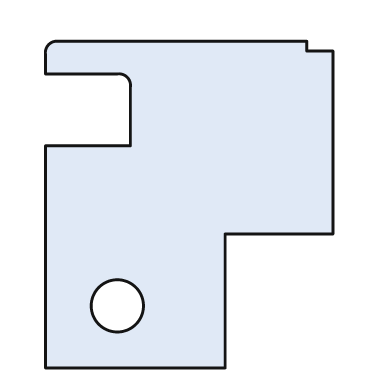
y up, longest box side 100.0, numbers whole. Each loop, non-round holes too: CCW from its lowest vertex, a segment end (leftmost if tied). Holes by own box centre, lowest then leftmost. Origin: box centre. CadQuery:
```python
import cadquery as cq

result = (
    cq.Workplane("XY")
    .moveTo(-44.0, -50.0)
    .lineTo(11.0, -50.0)
    .lineTo(11.0, -9.0)
    .lineTo(44.0, -9.0)
    .lineTo(44.0, 47.0)
    .lineTo(36.0, 47.0)
    .lineTo(36.0, 50.0)
    .lineTo(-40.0, 50.0)
    .threePointArc((-43.0, 49.0), (-44.0, 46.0))
    .lineTo(-44.0, 40.0)
    .lineTo(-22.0, 40.0)
    .threePointArc((-19.0, 39.0), (-18.0, 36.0))
    .lineTo(-18.0, 18.0)
    .lineTo(-44.0, 18.0)
    .close()
    .moveTo(-22.0, -31.0)
    .circle(8.0)
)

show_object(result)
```